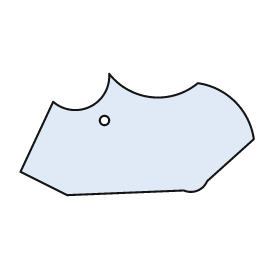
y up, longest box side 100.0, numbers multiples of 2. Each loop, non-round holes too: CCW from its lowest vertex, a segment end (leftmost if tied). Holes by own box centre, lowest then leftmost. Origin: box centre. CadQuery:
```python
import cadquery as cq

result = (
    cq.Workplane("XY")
    .moveTo(-30.0, -26.0)
    .lineTo(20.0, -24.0)
    .threePointArc((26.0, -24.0), (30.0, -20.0))
    .lineTo(50.0, -2.0)
    .threePointArc((42.0, 14.0), (26.0, 22.0))
    .threePointArc((6.0, 16.0), (-12.0, 26.0))
    .threePointArc((-20.0, 12.0), (-36.0, 14.0))
    .lineTo(-50.0, -16.0)
    .close()
    .moveTo(-14.0, 6.0)
    .circle(2.0)
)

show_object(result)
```